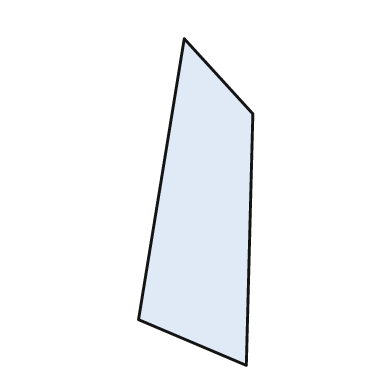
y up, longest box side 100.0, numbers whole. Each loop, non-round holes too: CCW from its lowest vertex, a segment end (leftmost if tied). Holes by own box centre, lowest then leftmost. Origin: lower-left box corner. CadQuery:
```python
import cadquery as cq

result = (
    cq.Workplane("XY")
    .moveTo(33.0, 0.0)
    .lineTo(35.0, 77.0)
    .lineTo(14.0, 100.0)
    .lineTo(0.0, 14.0)
    .close()
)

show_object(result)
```